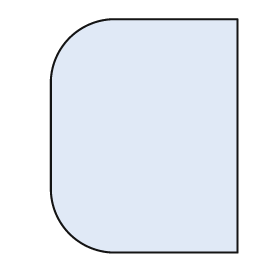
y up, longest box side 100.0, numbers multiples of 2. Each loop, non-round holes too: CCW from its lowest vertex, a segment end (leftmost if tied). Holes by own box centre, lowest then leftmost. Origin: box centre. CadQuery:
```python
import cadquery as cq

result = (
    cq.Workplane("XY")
    .moveTo(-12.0, -50.0)
    .lineTo(40.0, -50.0)
    .lineTo(40.0, 50.0)
    .lineTo(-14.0, 50.0)
    .threePointArc((-32.0, 42.0), (-40.0, 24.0))
    .lineTo(-40.0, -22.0)
    .threePointArc((-32.0, -42.0), (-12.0, -50.0))
    .close()
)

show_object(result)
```